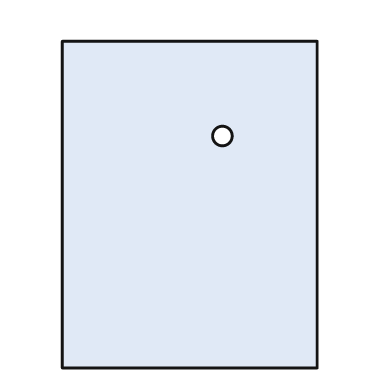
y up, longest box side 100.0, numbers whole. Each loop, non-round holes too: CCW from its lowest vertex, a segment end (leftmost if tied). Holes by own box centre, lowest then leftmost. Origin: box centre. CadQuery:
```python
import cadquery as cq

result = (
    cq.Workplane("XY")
    .moveTo(-39.0, -50.0)
    .lineTo(39.0, -50.0)
    .lineTo(39.0, 50.0)
    .lineTo(-39.0, 50.0)
    .close()
    .moveTo(10.0, 21.0)
    .circle(3.0)
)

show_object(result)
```